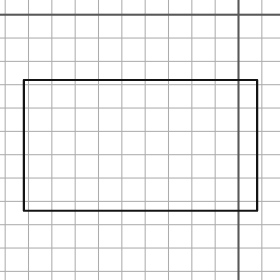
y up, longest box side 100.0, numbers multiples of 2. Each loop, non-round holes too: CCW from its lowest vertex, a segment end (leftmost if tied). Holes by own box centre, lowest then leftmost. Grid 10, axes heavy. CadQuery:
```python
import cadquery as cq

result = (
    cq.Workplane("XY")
    .moveTo(-92.0, -84.0)
    .lineTo(8.0, -84.0)
    .lineTo(8.0, -28.0)
    .lineTo(-92.0, -28.0)
    .close()
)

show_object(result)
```